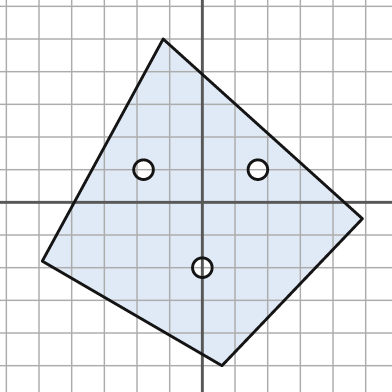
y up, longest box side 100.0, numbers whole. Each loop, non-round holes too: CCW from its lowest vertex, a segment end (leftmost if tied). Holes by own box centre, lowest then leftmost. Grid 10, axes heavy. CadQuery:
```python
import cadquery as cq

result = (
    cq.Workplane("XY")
    .moveTo(6.0, -50.0)
    .lineTo(49.0, -5.0)
    .lineTo(-12.0, 50.0)
    .lineTo(-49.0, -18.0)
    .close()
    .moveTo(0.0, -20.0)
    .circle(3.0)
    .moveTo(-18.0, 10.0)
    .circle(3.0)
    .moveTo(17.0, 10.0)
    .circle(3.0)
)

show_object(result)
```